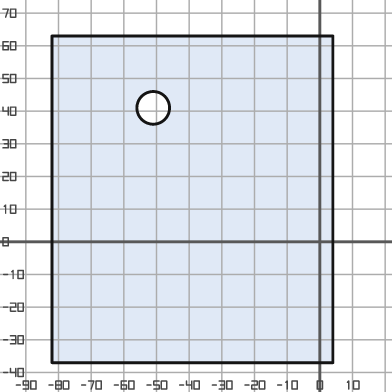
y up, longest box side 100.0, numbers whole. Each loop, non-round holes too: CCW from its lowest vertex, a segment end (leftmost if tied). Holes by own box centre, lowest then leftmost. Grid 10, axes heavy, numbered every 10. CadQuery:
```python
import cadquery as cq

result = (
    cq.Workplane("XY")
    .moveTo(-82.0, -37.0)
    .lineTo(4.0, -37.0)
    .lineTo(4.0, 63.0)
    .lineTo(-82.0, 63.0)
    .close()
    .moveTo(-51.0, 41.0)
    .circle(5.0)
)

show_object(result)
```